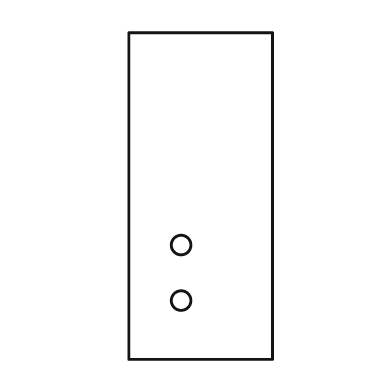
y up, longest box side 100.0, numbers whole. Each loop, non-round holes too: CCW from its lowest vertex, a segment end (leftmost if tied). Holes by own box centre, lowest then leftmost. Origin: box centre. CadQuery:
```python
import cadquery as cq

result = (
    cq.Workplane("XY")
    .moveTo(-22.0, -50.0)
    .lineTo(22.0, -50.0)
    .lineTo(22.0, 50.0)
    .lineTo(-22.0, 50.0)
    .close()
    .moveTo(-6.0, -32.0)
    .circle(3.0)
    .moveTo(-6.0, -15.0)
    .circle(3.0)
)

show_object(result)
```